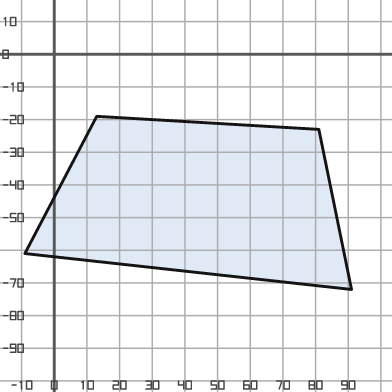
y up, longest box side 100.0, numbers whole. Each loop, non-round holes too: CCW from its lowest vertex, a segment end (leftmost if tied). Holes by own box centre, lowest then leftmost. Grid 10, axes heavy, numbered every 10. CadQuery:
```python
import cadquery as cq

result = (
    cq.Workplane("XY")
    .moveTo(91.0, -72.0)
    .lineTo(81.0, -23.0)
    .lineTo(13.0, -19.0)
    .lineTo(-9.0, -61.0)
    .close()
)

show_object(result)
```